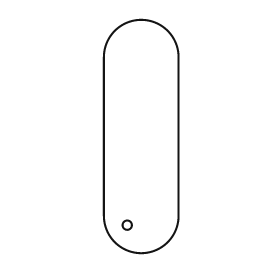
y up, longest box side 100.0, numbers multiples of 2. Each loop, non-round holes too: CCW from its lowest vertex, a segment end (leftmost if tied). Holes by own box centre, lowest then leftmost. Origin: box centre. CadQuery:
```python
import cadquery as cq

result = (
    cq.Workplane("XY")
    .moveTo(-16.0, -34.0)
    .threePointArc((0.0, -50.0), (16.0, -34.0))
    .lineTo(16.0, 34.0)
    .threePointArc((0.0, 50.0), (-16.0, 34.0))
    .close()
    .moveTo(-6.0, -38.0)
    .circle(2.0)
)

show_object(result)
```